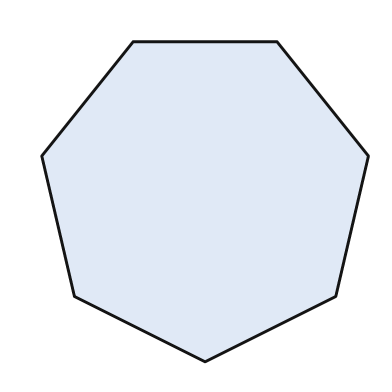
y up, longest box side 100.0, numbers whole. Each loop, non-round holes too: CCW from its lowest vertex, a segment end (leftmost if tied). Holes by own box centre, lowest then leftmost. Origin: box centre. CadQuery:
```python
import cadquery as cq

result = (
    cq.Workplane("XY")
    .moveTo(0.0, -49.0)
    .lineTo(40.0, -29.0)
    .lineTo(50.0, 14.0)
    .lineTo(22.0, 49.0)
    .lineTo(-22.0, 49.0)
    .lineTo(-50.0, 14.0)
    .lineTo(-40.0, -29.0)
    .close()
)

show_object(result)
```